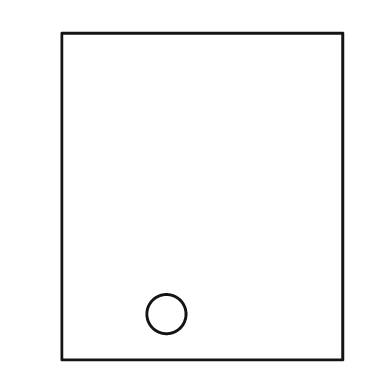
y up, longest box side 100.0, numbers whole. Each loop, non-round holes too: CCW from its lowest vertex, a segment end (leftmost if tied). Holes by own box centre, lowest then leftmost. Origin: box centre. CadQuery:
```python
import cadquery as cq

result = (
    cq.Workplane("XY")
    .moveTo(-43.0, -50.0)
    .lineTo(43.0, -50.0)
    .lineTo(43.0, 50.0)
    .lineTo(-43.0, 50.0)
    .close()
    .moveTo(-11.0, -36.0)
    .circle(6.0)
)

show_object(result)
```